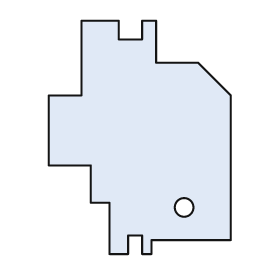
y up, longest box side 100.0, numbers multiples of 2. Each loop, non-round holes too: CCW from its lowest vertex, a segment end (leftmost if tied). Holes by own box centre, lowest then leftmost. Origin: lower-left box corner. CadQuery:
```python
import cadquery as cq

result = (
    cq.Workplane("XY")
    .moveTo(26.0, 0.0)
    .lineTo(34.0, 0.0)
    .lineTo(34.0, 8.0)
    .lineTo(40.0, 8.0)
    .lineTo(40.0, 0.0)
    .lineTo(44.0, 0.0)
    .lineTo(44.0, 6.0)
    .lineTo(78.0, 6.0)
    .lineTo(78.0, 68.0)
    .lineTo(64.0, 82.0)
    .lineTo(46.0, 82.0)
    .lineTo(46.0, 100.0)
    .lineTo(40.0, 100.0)
    .lineTo(40.0, 92.0)
    .lineTo(30.0, 92.0)
    .lineTo(30.0, 100.0)
    .lineTo(14.0, 100.0)
    .lineTo(14.0, 68.0)
    .lineTo(0.0, 68.0)
    .lineTo(0.0, 38.0)
    .lineTo(18.0, 38.0)
    .lineTo(18.0, 22.0)
    .lineTo(26.0, 22.0)
    .close()
    .moveTo(58.0, 20.0)
    .circle(4.0)
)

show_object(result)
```